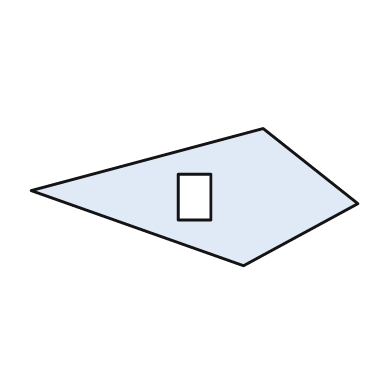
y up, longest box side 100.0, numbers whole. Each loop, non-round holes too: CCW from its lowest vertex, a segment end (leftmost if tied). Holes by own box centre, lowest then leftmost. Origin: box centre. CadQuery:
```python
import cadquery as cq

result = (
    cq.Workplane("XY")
    .moveTo(15.0, -21.0)
    .lineTo(50.0, -2.0)
    .lineTo(21.0, 21.0)
    .lineTo(-50.0, 2.0)
    .close()
    .moveTo(-5.0, -7.0)
    .lineTo(5.0, -7.0)
    .lineTo(5.0, 7.0)
    .lineTo(-5.0, 7.0)
    .close()
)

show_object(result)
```